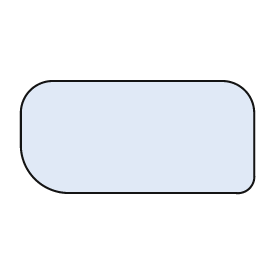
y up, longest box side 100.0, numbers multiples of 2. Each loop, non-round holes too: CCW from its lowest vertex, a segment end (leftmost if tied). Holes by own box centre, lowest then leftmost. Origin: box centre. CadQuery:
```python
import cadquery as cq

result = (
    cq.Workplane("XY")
    .moveTo(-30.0, -24.0)
    .lineTo(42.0, -24.0)
    .threePointArc((48.0, -22.0), (50.0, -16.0))
    .lineTo(50.0, 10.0)
    .threePointArc((46.0, 20.0), (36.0, 24.0))
    .lineTo(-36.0, 24.0)
    .threePointArc((-46.0, 20.0), (-50.0, 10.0))
    .lineTo(-50.0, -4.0)
    .threePointArc((-44.0, -18.0), (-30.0, -24.0))
    .close()
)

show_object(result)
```